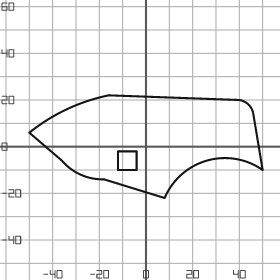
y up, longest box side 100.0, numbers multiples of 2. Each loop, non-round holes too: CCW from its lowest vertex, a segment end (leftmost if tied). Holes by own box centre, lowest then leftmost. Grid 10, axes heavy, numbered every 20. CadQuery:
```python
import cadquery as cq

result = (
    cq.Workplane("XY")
    .moveTo(8.0, -22.0)
    .threePointArc((26.0, -6.0), (50.0, -10.0))
    .lineTo(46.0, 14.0)
    .threePointArc((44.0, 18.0), (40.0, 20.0))
    .lineTo(-16.0, 22.0)
    .threePointArc((-34.0, 16.0), (-50.0, 6.0))
    .lineTo(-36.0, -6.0)
    .threePointArc((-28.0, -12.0), (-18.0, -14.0))
    .close()
    .moveTo(-12.0, -10.0)
    .lineTo(-4.0, -10.0)
    .lineTo(-4.0, -2.0)
    .lineTo(-12.0, -2.0)
    .close()
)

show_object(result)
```